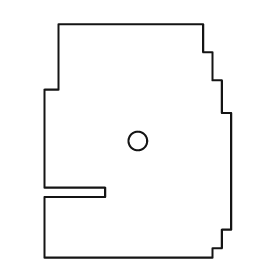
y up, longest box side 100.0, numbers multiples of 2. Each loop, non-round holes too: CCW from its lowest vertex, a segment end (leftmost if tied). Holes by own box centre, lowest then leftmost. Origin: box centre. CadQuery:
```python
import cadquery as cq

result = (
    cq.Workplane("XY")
    .moveTo(-40.0, -50.0)
    .lineTo(32.0, -50.0)
    .lineTo(32.0, -46.0)
    .lineTo(36.0, -46.0)
    .lineTo(36.0, -38.0)
    .lineTo(40.0, -38.0)
    .lineTo(40.0, 12.0)
    .lineTo(36.0, 12.0)
    .lineTo(36.0, 26.0)
    .lineTo(32.0, 26.0)
    .lineTo(32.0, 38.0)
    .lineTo(28.0, 38.0)
    .lineTo(28.0, 50.0)
    .lineTo(-34.0, 50.0)
    .lineTo(-34.0, 22.0)
    .lineTo(-40.0, 22.0)
    .lineTo(-40.0, -20.0)
    .lineTo(-14.0, -20.0)
    .lineTo(-14.0, -24.0)
    .lineTo(-40.0, -24.0)
    .close()
    .moveTo(0.0, 0.0)
    .circle(4.0)
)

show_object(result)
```